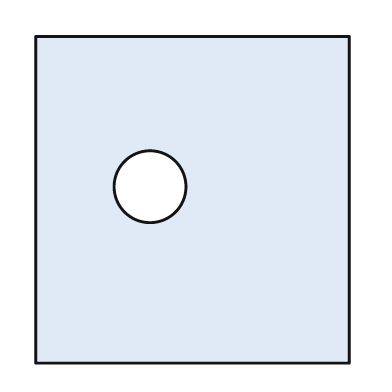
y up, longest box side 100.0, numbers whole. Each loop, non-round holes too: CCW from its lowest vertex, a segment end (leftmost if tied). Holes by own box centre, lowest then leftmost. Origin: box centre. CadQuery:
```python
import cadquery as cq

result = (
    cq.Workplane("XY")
    .moveTo(-48.0, -50.0)
    .lineTo(48.0, -50.0)
    .lineTo(48.0, 50.0)
    .lineTo(-48.0, 50.0)
    .close()
    .moveTo(-13.0, 4.0)
    .circle(11.0)
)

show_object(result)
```